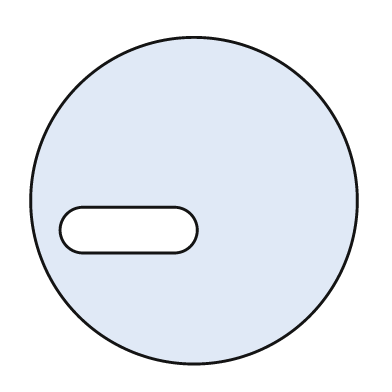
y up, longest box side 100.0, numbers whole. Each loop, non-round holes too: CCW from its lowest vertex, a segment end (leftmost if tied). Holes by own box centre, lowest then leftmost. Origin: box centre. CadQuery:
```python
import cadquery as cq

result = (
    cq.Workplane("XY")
    .moveTo(0.0, 0.0)
    .circle(50.0)
    .moveTo(-34.0, -16.0)
    .lineTo(-6.0, -16.0)
    .threePointArc((1.0, -9.0), (-6.0, -2.0))
    .lineTo(-34.0, -2.0)
    .threePointArc((-41.0, -9.0), (-34.0, -16.0))
    .close()
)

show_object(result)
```